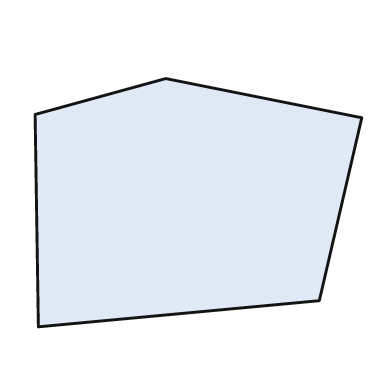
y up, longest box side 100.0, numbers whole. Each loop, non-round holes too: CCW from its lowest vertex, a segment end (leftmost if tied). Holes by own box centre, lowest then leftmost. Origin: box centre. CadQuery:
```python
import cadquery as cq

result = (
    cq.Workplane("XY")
    .moveTo(-49.0, -38.0)
    .lineTo(37.0, -30.0)
    .lineTo(50.0, 26.0)
    .lineTo(-10.0, 38.0)
    .lineTo(-50.0, 27.0)
    .close()
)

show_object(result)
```